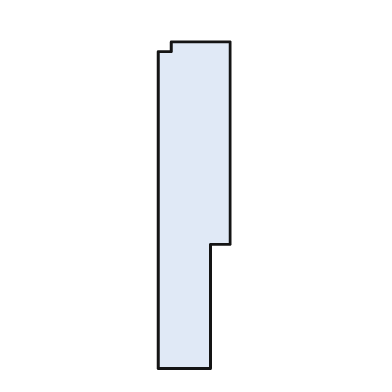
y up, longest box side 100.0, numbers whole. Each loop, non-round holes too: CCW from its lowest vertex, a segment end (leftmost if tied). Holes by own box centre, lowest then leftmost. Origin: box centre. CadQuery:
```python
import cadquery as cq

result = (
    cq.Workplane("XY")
    .moveTo(-11.0, -50.0)
    .lineTo(5.0, -50.0)
    .lineTo(5.0, -12.0)
    .lineTo(11.0, -12.0)
    .lineTo(11.0, 50.0)
    .lineTo(-7.0, 50.0)
    .lineTo(-7.0, 47.0)
    .lineTo(-11.0, 47.0)
    .close()
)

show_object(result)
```